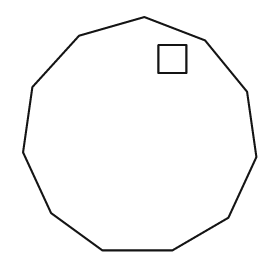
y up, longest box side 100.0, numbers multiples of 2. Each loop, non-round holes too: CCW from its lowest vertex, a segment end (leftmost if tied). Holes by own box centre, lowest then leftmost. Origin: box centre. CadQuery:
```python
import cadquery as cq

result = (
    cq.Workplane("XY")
    .moveTo(-16.0, -50.0)
    .lineTo(14.0, -50.0)
    .lineTo(38.0, -36.0)
    .lineTo(50.0, -10.0)
    .lineTo(46.0, 18.0)
    .lineTo(28.0, 40.0)
    .lineTo(2.0, 50.0)
    .lineTo(-26.0, 42.0)
    .lineTo(-46.0, 20.0)
    .lineTo(-50.0, -8.0)
    .lineTo(-38.0, -34.0)
    .close()
    .moveTo(8.0, 26.0)
    .lineTo(20.0, 26.0)
    .lineTo(20.0, 38.0)
    .lineTo(8.0, 38.0)
    .close()
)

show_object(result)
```